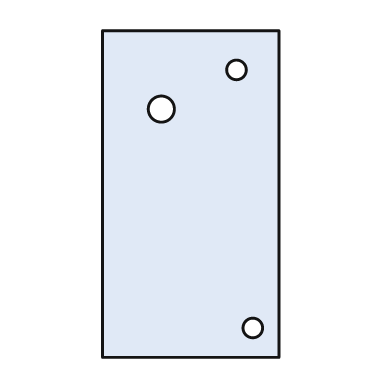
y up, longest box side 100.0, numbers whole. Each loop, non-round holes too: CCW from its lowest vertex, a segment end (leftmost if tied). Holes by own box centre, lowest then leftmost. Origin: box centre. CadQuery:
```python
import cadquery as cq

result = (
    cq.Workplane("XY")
    .moveTo(-27.0, -50.0)
    .lineTo(27.0, -50.0)
    .lineTo(27.0, 50.0)
    .lineTo(-27.0, 50.0)
    .close()
    .moveTo(19.0, -41.0)
    .circle(3.0)
    .moveTo(-9.0, 26.0)
    .circle(4.0)
    .moveTo(14.0, 38.0)
    .circle(3.0)
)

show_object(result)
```